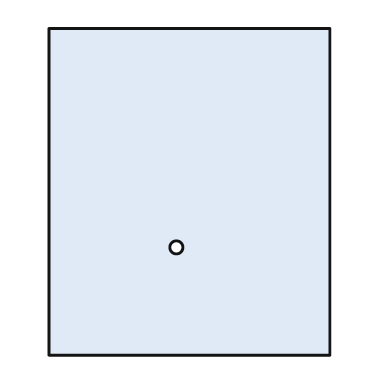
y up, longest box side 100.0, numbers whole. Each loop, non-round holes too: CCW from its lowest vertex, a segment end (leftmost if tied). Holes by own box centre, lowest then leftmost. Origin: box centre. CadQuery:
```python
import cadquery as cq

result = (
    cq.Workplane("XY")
    .moveTo(-43.0, -50.0)
    .lineTo(43.0, -50.0)
    .lineTo(43.0, 50.0)
    .lineTo(-43.0, 50.0)
    .close()
    .moveTo(-4.0, -17.0)
    .circle(2.0)
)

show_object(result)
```